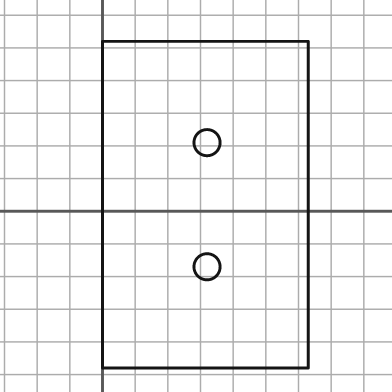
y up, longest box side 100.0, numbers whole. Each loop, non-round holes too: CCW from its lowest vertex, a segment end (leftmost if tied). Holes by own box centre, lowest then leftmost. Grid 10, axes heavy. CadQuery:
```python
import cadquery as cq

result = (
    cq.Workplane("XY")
    .moveTo(0.0, -48.0)
    .lineTo(63.0, -48.0)
    .lineTo(63.0, 52.0)
    .lineTo(0.0, 52.0)
    .close()
    .moveTo(32.0, -17.0)
    .circle(4.0)
    .moveTo(32.0, 21.0)
    .circle(4.0)
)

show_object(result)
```